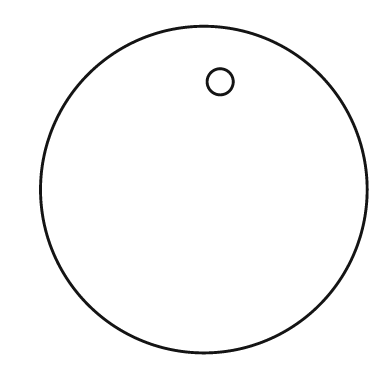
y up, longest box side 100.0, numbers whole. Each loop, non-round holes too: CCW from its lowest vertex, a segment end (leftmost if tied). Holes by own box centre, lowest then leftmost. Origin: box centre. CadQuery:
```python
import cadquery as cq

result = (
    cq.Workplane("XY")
    .moveTo(0.0, 0.0)
    .circle(50.0)
    .moveTo(5.0, 33.0)
    .circle(4.0)
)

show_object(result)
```